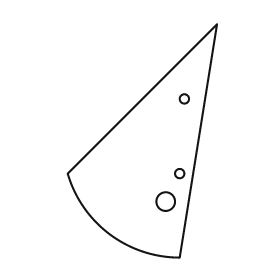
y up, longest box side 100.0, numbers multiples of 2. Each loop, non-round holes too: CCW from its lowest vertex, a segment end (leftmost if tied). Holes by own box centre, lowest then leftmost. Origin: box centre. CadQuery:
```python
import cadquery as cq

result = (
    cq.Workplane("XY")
    .moveTo(16.0, -50.0)
    .lineTo(32.0, 50.0)
    .lineTo(-32.0, -14.0)
    .threePointArc((-14.0, -40.0), (16.0, -50.0))
    .close()
    .moveTo(10.0, -26.0)
    .circle(4.0)
    .moveTo(16.0, -14.0)
    .circle(2.0)
    .moveTo(18.0, 18.0)
    .circle(2.0)
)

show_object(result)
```